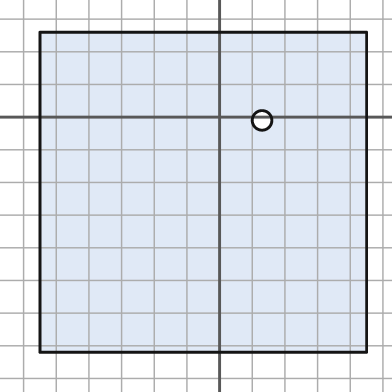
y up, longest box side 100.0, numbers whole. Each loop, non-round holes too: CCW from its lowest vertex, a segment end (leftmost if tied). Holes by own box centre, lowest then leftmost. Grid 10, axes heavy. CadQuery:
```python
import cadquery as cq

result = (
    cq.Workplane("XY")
    .moveTo(-55.0, -72.0)
    .lineTo(45.0, -72.0)
    .lineTo(45.0, 26.0)
    .lineTo(-55.0, 26.0)
    .close()
    .moveTo(13.0, -1.0)
    .circle(3.0)
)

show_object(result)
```